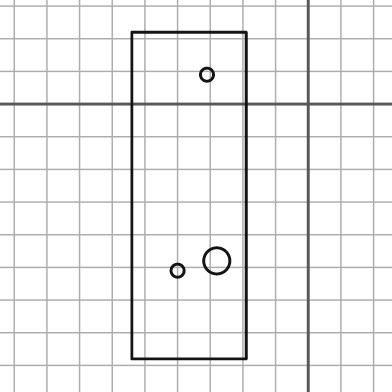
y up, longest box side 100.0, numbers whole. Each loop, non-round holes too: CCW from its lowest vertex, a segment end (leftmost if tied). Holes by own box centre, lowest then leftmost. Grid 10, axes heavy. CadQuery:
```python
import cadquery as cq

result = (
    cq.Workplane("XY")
    .moveTo(-54.0, -78.0)
    .lineTo(-19.0, -78.0)
    .lineTo(-19.0, 22.0)
    .lineTo(-54.0, 22.0)
    .close()
    .moveTo(-40.0, -51.0)
    .circle(2.0)
    .moveTo(-28.0, -48.0)
    .circle(4.0)
    .moveTo(-31.0, 9.0)
    .circle(2.0)
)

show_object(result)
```